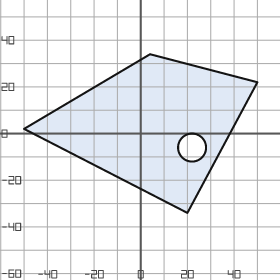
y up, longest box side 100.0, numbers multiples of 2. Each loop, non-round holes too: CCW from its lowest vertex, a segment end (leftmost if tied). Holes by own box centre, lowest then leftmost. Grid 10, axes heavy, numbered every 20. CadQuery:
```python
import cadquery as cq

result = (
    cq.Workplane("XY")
    .moveTo(20.0, -34.0)
    .lineTo(50.0, 22.0)
    .lineTo(4.0, 34.0)
    .lineTo(-50.0, 2.0)
    .close()
    .moveTo(22.0, -6.0)
    .circle(6.0)
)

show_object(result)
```